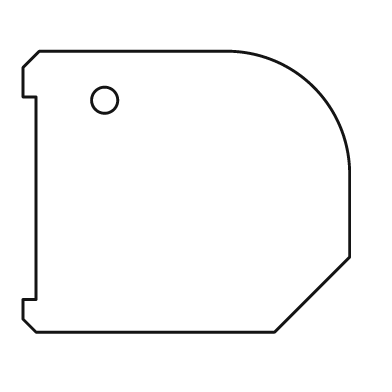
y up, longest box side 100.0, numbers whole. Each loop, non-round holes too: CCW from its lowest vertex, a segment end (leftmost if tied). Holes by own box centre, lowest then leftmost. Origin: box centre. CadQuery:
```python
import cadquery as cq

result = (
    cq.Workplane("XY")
    .moveTo(-46.0, -43.0)
    .lineTo(27.0, -43.0)
    .lineTo(50.0, -20.0)
    .lineTo(50.0, 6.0)
    .threePointArc((39.0, 32.0), (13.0, 43.0))
    .lineTo(-45.0, 43.0)
    .lineTo(-50.0, 38.0)
    .lineTo(-50.0, 29.0)
    .lineTo(-46.0, 29.0)
    .lineTo(-46.0, -33.0)
    .lineTo(-50.0, -33.0)
    .lineTo(-50.0, -39.0)
    .close()
    .moveTo(-25.0, 28.0)
    .circle(4.0)
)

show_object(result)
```